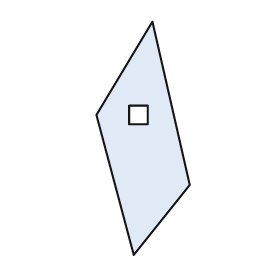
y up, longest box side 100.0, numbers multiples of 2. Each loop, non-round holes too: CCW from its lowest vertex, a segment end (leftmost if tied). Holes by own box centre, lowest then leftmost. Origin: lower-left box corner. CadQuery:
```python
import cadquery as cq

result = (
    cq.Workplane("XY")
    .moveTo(16.0, 0.0)
    .lineTo(40.0, 30.0)
    .lineTo(24.0, 100.0)
    .lineTo(0.0, 60.0)
    .close()
    .moveTo(14.0, 56.0)
    .lineTo(22.0, 56.0)
    .lineTo(22.0, 64.0)
    .lineTo(14.0, 64.0)
    .close()
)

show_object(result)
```